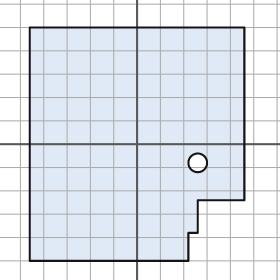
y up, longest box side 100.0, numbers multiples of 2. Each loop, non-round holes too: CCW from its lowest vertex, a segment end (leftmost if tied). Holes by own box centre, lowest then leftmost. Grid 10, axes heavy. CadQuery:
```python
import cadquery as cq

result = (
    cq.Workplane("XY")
    .moveTo(-46.0, -50.0)
    .lineTo(22.0, -50.0)
    .lineTo(22.0, -38.0)
    .lineTo(26.0, -38.0)
    .lineTo(26.0, -24.0)
    .lineTo(46.0, -24.0)
    .lineTo(46.0, 50.0)
    .lineTo(-46.0, 50.0)
    .close()
    .moveTo(26.0, -8.0)
    .circle(4.0)
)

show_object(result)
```